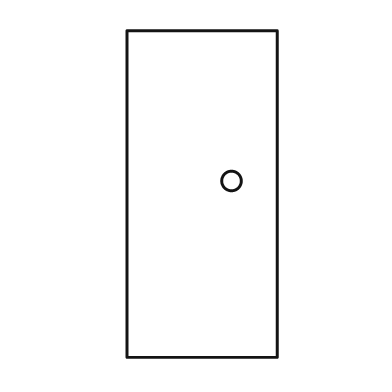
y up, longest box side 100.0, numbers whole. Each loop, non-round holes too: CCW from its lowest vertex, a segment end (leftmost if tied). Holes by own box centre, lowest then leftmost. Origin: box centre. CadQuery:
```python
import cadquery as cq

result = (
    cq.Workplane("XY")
    .moveTo(-23.0, -50.0)
    .lineTo(23.0, -50.0)
    .lineTo(23.0, 50.0)
    .lineTo(-23.0, 50.0)
    .close()
    .moveTo(9.0, 4.0)
    .circle(3.0)
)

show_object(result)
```